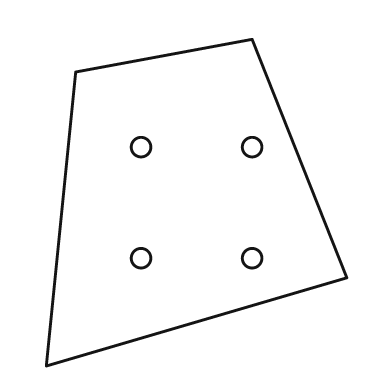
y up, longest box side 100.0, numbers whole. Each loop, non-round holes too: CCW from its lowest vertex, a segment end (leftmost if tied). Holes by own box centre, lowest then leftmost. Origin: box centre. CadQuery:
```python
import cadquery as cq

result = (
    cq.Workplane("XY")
    .moveTo(-46.0, -50.0)
    .lineTo(46.0, -23.0)
    .lineTo(17.0, 50.0)
    .lineTo(-37.0, 40.0)
    .close()
    .moveTo(-17.0, -17.0)
    .circle(3.0)
    .moveTo(17.0, -17.0)
    .circle(3.0)
    .moveTo(-17.0, 17.0)
    .circle(3.0)
    .moveTo(17.0, 17.0)
    .circle(3.0)
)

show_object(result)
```